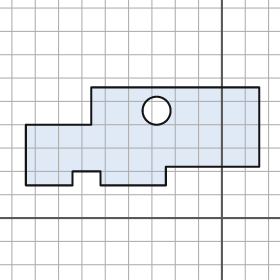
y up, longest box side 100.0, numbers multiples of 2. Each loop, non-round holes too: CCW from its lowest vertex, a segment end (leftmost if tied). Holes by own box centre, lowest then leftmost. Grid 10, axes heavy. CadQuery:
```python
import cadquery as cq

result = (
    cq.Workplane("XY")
    .moveTo(-84.0, 14.0)
    .lineTo(-64.0, 14.0)
    .lineTo(-64.0, 20.0)
    .lineTo(-52.0, 20.0)
    .lineTo(-52.0, 14.0)
    .lineTo(-24.0, 14.0)
    .lineTo(-24.0, 22.0)
    .lineTo(16.0, 22.0)
    .lineTo(16.0, 56.0)
    .lineTo(-56.0, 56.0)
    .lineTo(-56.0, 40.0)
    .lineTo(-84.0, 40.0)
    .close()
    .moveTo(-28.0, 46.0)
    .circle(6.0)
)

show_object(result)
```